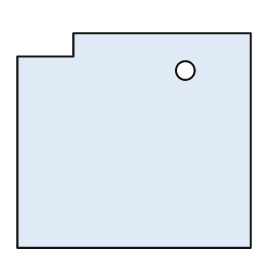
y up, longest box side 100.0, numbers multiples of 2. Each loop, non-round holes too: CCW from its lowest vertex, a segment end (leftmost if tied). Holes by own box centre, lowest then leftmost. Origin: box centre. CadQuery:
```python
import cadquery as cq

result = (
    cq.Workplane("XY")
    .moveTo(-50.0, -46.0)
    .lineTo(50.0, -46.0)
    .lineTo(50.0, 46.0)
    .lineTo(-26.0, 46.0)
    .lineTo(-26.0, 36.0)
    .lineTo(-50.0, 36.0)
    .close()
    .moveTo(22.0, 30.0)
    .circle(4.0)
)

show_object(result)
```